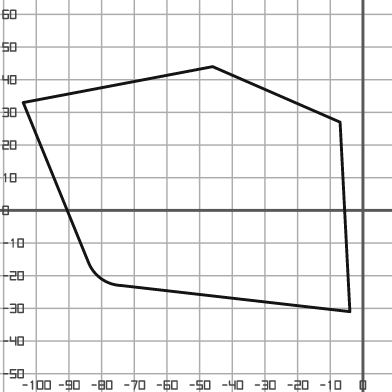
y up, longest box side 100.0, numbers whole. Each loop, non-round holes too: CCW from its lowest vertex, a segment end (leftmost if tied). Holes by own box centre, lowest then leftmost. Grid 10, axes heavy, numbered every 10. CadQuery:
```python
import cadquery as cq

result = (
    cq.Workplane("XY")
    .moveTo(-4.0, -31.0)
    .lineTo(-7.0, 27.0)
    .lineTo(-46.0, 44.0)
    .lineTo(-104.0, 33.0)
    .lineTo(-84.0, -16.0)
    .threePointArc((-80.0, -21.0), (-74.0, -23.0))
    .close()
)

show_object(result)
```